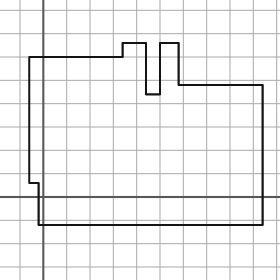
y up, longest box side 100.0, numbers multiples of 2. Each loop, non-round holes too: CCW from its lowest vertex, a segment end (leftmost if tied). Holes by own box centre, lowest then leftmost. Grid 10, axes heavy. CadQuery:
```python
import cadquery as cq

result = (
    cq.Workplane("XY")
    .moveTo(-2.0, -12.0)
    .lineTo(94.0, -12.0)
    .lineTo(94.0, 48.0)
    .lineTo(58.0, 48.0)
    .lineTo(58.0, 66.0)
    .lineTo(50.0, 66.0)
    .lineTo(50.0, 44.0)
    .lineTo(44.0, 44.0)
    .lineTo(44.0, 66.0)
    .lineTo(34.0, 66.0)
    .lineTo(34.0, 60.0)
    .lineTo(-6.0, 60.0)
    .lineTo(-6.0, 6.0)
    .lineTo(-2.0, 6.0)
    .close()
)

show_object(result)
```